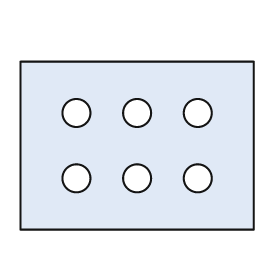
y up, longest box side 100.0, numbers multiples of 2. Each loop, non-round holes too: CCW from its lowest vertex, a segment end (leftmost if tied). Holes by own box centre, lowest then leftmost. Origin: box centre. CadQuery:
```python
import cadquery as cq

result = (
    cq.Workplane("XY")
    .moveTo(-50.0, -36.0)
    .lineTo(50.0, -36.0)
    .lineTo(50.0, 36.0)
    .lineTo(-50.0, 36.0)
    .close()
    .moveTo(-26.0, -14.0)
    .circle(6.0)
    .moveTo(0.0, -14.0)
    .circle(6.0)
    .moveTo(26.0, -14.0)
    .circle(6.0)
    .moveTo(-26.0, 14.0)
    .circle(6.0)
    .moveTo(0.0, 14.0)
    .circle(6.0)
    .moveTo(26.0, 14.0)
    .circle(6.0)
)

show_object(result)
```